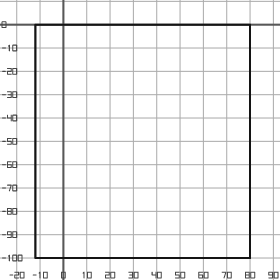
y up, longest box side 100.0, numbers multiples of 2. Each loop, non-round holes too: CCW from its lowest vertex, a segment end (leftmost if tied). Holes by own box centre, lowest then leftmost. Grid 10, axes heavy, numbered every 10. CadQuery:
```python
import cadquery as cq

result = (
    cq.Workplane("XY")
    .moveTo(-12.0, -100.0)
    .lineTo(80.0, -100.0)
    .lineTo(80.0, 0.0)
    .lineTo(-12.0, 0.0)
    .close()
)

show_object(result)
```